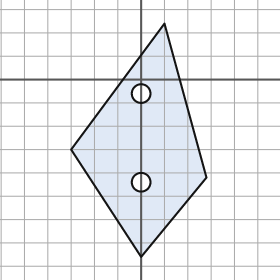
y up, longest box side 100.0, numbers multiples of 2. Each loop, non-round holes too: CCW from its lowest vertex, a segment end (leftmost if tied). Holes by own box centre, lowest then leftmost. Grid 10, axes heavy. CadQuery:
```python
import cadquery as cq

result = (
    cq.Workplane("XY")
    .moveTo(0.0, -76.0)
    .lineTo(28.0, -42.0)
    .lineTo(10.0, 24.0)
    .lineTo(-30.0, -30.0)
    .close()
    .moveTo(0.0, -44.0)
    .circle(4.0)
    .moveTo(0.0, -6.0)
    .circle(4.0)
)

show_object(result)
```